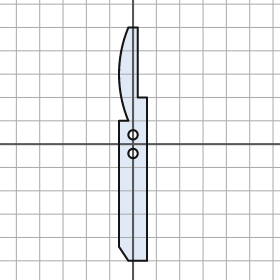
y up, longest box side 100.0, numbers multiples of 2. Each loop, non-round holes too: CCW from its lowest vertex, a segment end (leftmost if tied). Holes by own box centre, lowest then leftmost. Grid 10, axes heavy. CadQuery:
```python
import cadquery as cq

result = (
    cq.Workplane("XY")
    .moveTo(-2.0, -50.0)
    .lineTo(6.0, -50.0)
    .lineTo(6.0, 20.0)
    .lineTo(2.0, 20.0)
    .lineTo(2.0, 50.0)
    .lineTo(-2.0, 50.0)
    .threePointArc((-6.0, 30.0), (-2.0, 10.0))
    .lineTo(-6.0, 10.0)
    .lineTo(-6.0, -44.0)
    .close()
    .moveTo(0.0, -4.0)
    .circle(2.0)
    .moveTo(0.0, 4.0)
    .circle(2.0)
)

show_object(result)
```